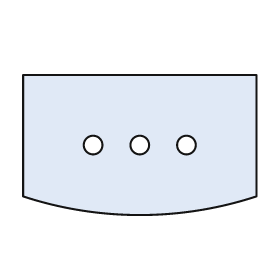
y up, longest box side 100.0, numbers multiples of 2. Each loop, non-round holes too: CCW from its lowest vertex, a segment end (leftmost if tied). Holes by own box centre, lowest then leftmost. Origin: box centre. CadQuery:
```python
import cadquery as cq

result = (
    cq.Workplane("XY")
    .moveTo(-50.0, -22.0)
    .threePointArc((0.0, -30.0), (50.0, -22.0))
    .lineTo(50.0, 30.0)
    .lineTo(-50.0, 30.0)
    .close()
    .moveTo(-20.0, 0.0)
    .circle(4.0)
    .moveTo(0.0, 0.0)
    .circle(4.0)
    .moveTo(20.0, 0.0)
    .circle(4.0)
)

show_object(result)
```